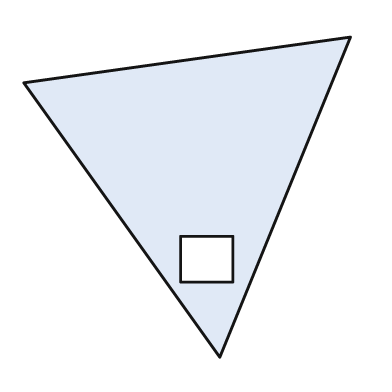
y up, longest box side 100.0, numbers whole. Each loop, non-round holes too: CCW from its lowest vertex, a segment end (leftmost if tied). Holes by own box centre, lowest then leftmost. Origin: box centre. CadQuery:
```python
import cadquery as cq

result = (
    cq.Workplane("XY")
    .moveTo(10.0, -49.0)
    .lineTo(50.0, 49.0)
    .lineTo(-50.0, 35.0)
    .close()
    .moveTo(-2.0, -26.0)
    .lineTo(14.0, -26.0)
    .lineTo(14.0, -12.0)
    .lineTo(-2.0, -12.0)
    .close()
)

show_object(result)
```